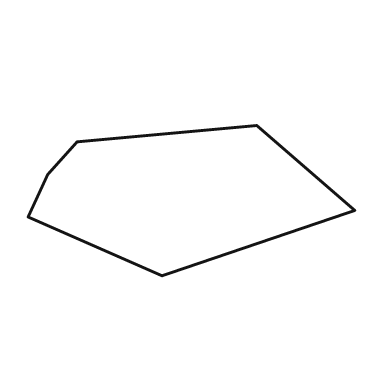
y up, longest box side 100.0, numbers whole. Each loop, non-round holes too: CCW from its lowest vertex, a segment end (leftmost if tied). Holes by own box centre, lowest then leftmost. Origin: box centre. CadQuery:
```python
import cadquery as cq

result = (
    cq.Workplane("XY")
    .moveTo(-9.0, -23.0)
    .lineTo(50.0, -3.0)
    .lineTo(20.0, 23.0)
    .lineTo(-35.0, 18.0)
    .lineTo(-44.0, 8.0)
    .lineTo(-50.0, -5.0)
    .close()
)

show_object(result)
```